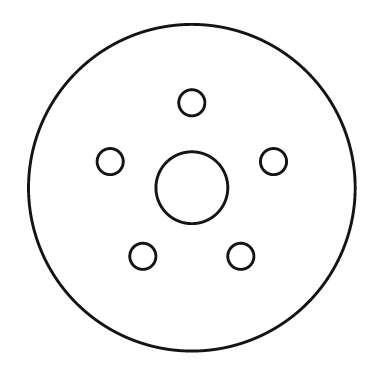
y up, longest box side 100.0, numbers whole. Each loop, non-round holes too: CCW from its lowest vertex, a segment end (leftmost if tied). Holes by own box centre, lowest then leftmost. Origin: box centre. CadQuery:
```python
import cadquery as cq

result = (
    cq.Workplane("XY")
    .moveTo(0.0, 0.0)
    .circle(50.0)
    .moveTo(-15.0, -21.0)
    .circle(4.0)
    .moveTo(15.0, -21.0)
    .circle(4.0)
    .moveTo(0.0, 0.0)
    .circle(11.0)
    .moveTo(-25.0, 8.0)
    .circle(4.0)
    .moveTo(25.0, 8.0)
    .circle(4.0)
    .moveTo(0.0, 26.0)
    .circle(4.0)
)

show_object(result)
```